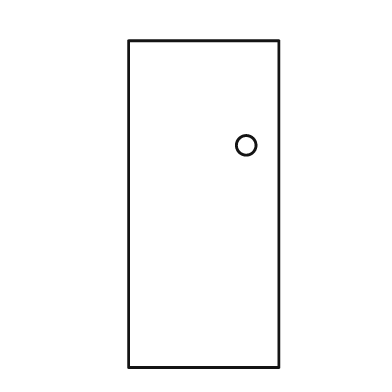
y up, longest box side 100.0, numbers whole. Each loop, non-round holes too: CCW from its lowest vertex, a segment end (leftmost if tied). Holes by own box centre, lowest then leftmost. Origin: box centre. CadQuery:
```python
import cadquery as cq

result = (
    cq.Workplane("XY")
    .moveTo(-23.0, -50.0)
    .lineTo(23.0, -50.0)
    .lineTo(23.0, 50.0)
    .lineTo(-23.0, 50.0)
    .close()
    .moveTo(13.0, 18.0)
    .circle(3.0)
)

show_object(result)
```